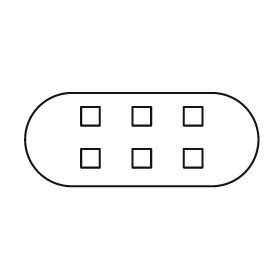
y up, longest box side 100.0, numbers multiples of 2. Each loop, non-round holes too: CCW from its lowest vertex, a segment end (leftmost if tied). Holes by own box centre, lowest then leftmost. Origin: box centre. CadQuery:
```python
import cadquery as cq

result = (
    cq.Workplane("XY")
    .moveTo(-30.0, -20.0)
    .lineTo(30.0, -20.0)
    .threePointArc((50.0, 0.0), (30.0, 20.0))
    .lineTo(-30.0, 20.0)
    .threePointArc((-50.0, 0.0), (-30.0, -20.0))
    .close()
    .moveTo(-26.0, -12.0)
    .lineTo(-18.0, -12.0)
    .lineTo(-18.0, -4.0)
    .lineTo(-26.0, -4.0)
    .close()
    .moveTo(-4.0, -12.0)
    .lineTo(4.0, -12.0)
    .lineTo(4.0, -4.0)
    .lineTo(-4.0, -4.0)
    .close()
    .moveTo(18.0, -12.0)
    .lineTo(26.0, -12.0)
    .lineTo(26.0, -4.0)
    .lineTo(18.0, -4.0)
    .close()
    .moveTo(-26.0, 6.0)
    .lineTo(-18.0, 6.0)
    .lineTo(-18.0, 14.0)
    .lineTo(-26.0, 14.0)
    .close()
    .moveTo(-4.0, 6.0)
    .lineTo(4.0, 6.0)
    .lineTo(4.0, 14.0)
    .lineTo(-4.0, 14.0)
    .close()
    .moveTo(18.0, 6.0)
    .lineTo(26.0, 6.0)
    .lineTo(26.0, 14.0)
    .lineTo(18.0, 14.0)
    .close()
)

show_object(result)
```